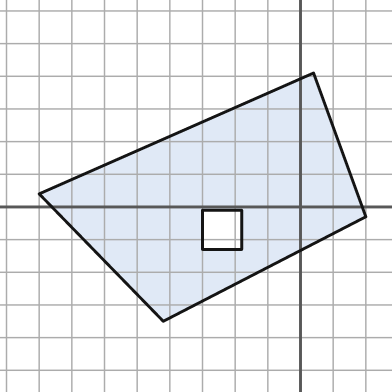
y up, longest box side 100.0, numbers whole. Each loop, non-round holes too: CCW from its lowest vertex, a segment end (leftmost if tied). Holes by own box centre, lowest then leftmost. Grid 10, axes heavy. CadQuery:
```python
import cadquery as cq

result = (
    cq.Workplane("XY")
    .moveTo(-42.0, -35.0)
    .lineTo(20.0, -3.0)
    .lineTo(4.0, 41.0)
    .lineTo(-80.0, 4.0)
    .close()
    .moveTo(-30.0, -13.0)
    .lineTo(-18.0, -13.0)
    .lineTo(-18.0, -1.0)
    .lineTo(-30.0, -1.0)
    .close()
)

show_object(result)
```